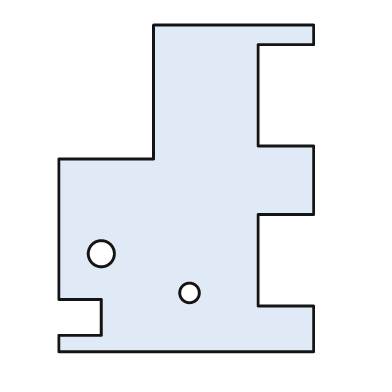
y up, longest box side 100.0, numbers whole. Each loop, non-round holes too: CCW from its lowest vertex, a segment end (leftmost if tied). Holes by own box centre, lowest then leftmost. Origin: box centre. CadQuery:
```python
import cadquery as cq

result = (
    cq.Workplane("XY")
    .moveTo(-39.0, -50.0)
    .lineTo(39.0, -50.0)
    .lineTo(39.0, -36.0)
    .lineTo(22.0, -36.0)
    .lineTo(22.0, -8.0)
    .lineTo(39.0, -8.0)
    .lineTo(39.0, 13.0)
    .lineTo(22.0, 13.0)
    .lineTo(22.0, 44.0)
    .lineTo(39.0, 44.0)
    .lineTo(39.0, 50.0)
    .lineTo(-10.0, 50.0)
    .lineTo(-10.0, 9.0)
    .lineTo(-39.0, 9.0)
    .lineTo(-39.0, -34.0)
    .lineTo(-26.0, -34.0)
    .lineTo(-26.0, -45.0)
    .lineTo(-39.0, -45.0)
    .close()
    .moveTo(1.0, -32.0)
    .circle(3.0)
    .moveTo(-26.0, -20.0)
    .circle(4.0)
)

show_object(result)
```